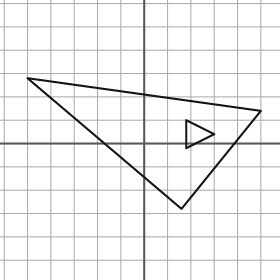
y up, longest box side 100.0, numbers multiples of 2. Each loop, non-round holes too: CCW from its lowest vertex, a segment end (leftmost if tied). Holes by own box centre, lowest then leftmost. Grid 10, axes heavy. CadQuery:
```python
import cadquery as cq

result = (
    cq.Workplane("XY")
    .moveTo(16.0, -28.0)
    .lineTo(50.0, 14.0)
    .lineTo(-50.0, 28.0)
    .close()
    .moveTo(18.0, -2.0)
    .lineTo(30.0, 4.0)
    .lineTo(18.0, 10.0)
    .close()
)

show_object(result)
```